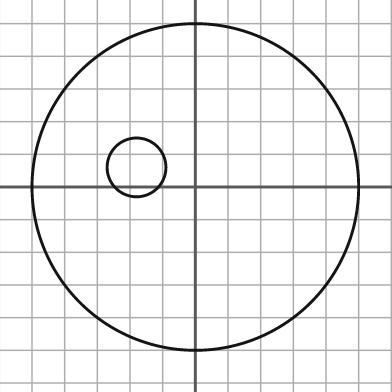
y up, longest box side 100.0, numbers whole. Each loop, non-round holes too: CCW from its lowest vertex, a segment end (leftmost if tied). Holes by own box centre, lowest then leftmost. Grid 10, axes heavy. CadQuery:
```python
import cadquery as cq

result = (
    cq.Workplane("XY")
    .moveTo(0.0, 0.0)
    .circle(50.0)
    .moveTo(-18.0, 6.0)
    .circle(9.0)
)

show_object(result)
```